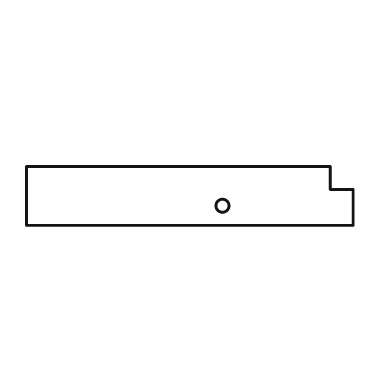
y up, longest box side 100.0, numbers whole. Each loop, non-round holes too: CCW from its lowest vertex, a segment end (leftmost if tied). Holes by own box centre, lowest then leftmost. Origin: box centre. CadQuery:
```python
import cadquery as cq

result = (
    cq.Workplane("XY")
    .moveTo(-50.0, -9.0)
    .lineTo(50.0, -9.0)
    .lineTo(50.0, 2.0)
    .lineTo(43.0, 2.0)
    .lineTo(43.0, 9.0)
    .lineTo(-50.0, 9.0)
    .close()
    .moveTo(10.0, -3.0)
    .circle(2.0)
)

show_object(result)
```